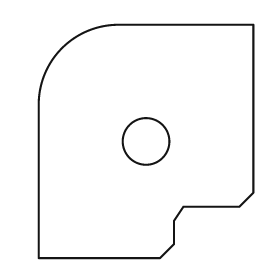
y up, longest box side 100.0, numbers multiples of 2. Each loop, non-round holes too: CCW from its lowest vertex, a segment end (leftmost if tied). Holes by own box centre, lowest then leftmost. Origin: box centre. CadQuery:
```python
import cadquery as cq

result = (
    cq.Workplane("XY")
    .moveTo(-46.0, -50.0)
    .lineTo(6.0, -50.0)
    .lineTo(12.0, -44.0)
    .lineTo(12.0, -34.0)
    .lineTo(16.0, -28.0)
    .lineTo(40.0, -28.0)
    .lineTo(46.0, -22.0)
    .lineTo(46.0, 50.0)
    .lineTo(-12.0, 50.0)
    .threePointArc((-36.0, 40.0), (-46.0, 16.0))
    .close()
    .moveTo(0.0, 0.0)
    .circle(10.0)
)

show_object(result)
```